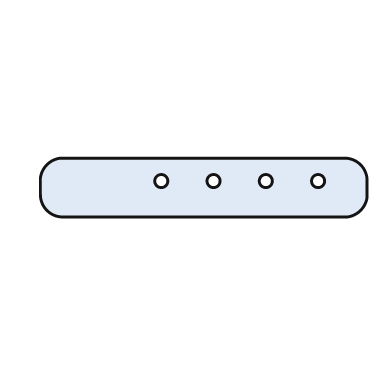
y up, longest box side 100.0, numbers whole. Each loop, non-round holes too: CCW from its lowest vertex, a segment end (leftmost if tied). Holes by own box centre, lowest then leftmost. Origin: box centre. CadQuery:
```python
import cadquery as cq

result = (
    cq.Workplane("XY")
    .moveTo(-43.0, -9.0)
    .lineTo(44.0, -9.0)
    .threePointArc((48.0, -7.0), (50.0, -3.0))
    .lineTo(50.0, 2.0)
    .threePointArc((48.0, 7.0), (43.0, 9.0))
    .lineTo(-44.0, 9.0)
    .threePointArc((-48.0, 7.0), (-50.0, 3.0))
    .lineTo(-50.0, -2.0)
    .threePointArc((-48.0, -7.0), (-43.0, -9.0))
    .close()
    .moveTo(-13.0, 2.0)
    .circle(2.0)
    .moveTo(3.0, 2.0)
    .circle(2.0)
    .moveTo(19.0, 2.0)
    .circle(2.0)
    .moveTo(35.0, 2.0)
    .circle(2.0)
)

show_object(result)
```